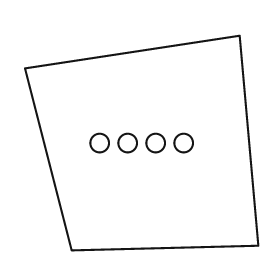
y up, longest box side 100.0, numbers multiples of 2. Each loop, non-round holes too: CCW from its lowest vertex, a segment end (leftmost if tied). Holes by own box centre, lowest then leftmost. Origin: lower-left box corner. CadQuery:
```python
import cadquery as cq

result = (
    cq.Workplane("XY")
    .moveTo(20.0, 0.0)
    .lineTo(100.0, 2.0)
    .lineTo(92.0, 92.0)
    .lineTo(0.0, 78.0)
    .close()
    .moveTo(32.0, 46.0)
    .circle(4.0)
    .moveTo(44.0, 46.0)
    .circle(4.0)
    .moveTo(56.0, 46.0)
    .circle(4.0)
    .moveTo(68.0, 46.0)
    .circle(4.0)
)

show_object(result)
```